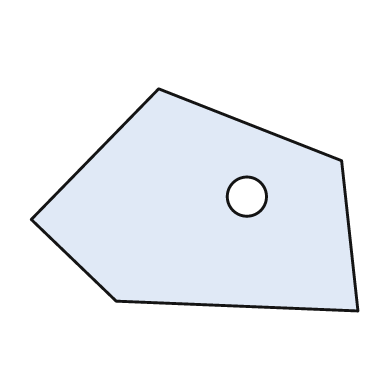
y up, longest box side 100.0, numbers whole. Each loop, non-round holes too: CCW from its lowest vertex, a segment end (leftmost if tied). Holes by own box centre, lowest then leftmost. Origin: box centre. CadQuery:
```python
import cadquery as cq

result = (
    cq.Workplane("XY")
    .moveTo(50.0, -34.0)
    .lineTo(45.0, 12.0)
    .lineTo(-11.0, 34.0)
    .lineTo(-50.0, -6.0)
    .lineTo(-24.0, -31.0)
    .close()
    .moveTo(16.0, 1.0)
    .circle(6.0)
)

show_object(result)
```